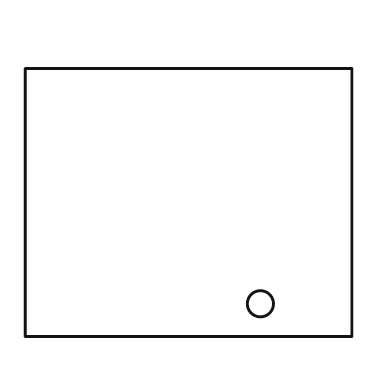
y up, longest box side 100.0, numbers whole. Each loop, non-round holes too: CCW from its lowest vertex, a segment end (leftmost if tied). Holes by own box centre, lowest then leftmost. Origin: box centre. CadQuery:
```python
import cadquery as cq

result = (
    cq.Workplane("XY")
    .moveTo(-50.0, -41.0)
    .lineTo(50.0, -41.0)
    .lineTo(50.0, 41.0)
    .lineTo(-50.0, 41.0)
    .close()
    .moveTo(22.0, -31.0)
    .circle(4.0)
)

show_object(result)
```